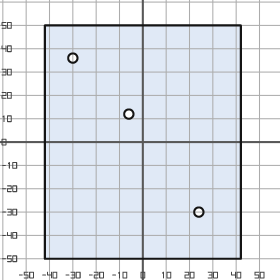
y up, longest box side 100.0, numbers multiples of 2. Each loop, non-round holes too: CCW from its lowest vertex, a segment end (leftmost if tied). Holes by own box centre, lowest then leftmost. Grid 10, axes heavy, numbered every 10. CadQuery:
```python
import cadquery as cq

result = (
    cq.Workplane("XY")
    .moveTo(-42.0, -50.0)
    .lineTo(42.0, -50.0)
    .lineTo(42.0, 50.0)
    .lineTo(-42.0, 50.0)
    .close()
    .moveTo(24.0, -30.0)
    .circle(2.0)
    .moveTo(-6.0, 12.0)
    .circle(2.0)
    .moveTo(-30.0, 36.0)
    .circle(2.0)
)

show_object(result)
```